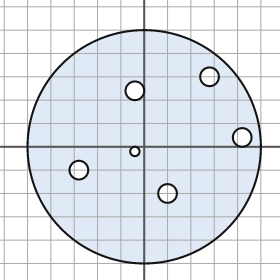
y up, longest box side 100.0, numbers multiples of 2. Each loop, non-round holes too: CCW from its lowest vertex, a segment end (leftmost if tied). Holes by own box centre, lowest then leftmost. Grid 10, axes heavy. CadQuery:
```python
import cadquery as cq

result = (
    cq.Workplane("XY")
    .moveTo(0.0, 0.0)
    .circle(50.0)
    .moveTo(10.0, -20.0)
    .circle(4.0)
    .moveTo(-28.0, -10.0)
    .circle(4.0)
    .moveTo(-4.0, -2.0)
    .circle(2.0)
    .moveTo(42.0, 4.0)
    .circle(4.0)
    .moveTo(-4.0, 24.0)
    .circle(4.0)
    .moveTo(28.0, 30.0)
    .circle(4.0)
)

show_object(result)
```